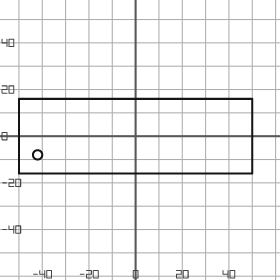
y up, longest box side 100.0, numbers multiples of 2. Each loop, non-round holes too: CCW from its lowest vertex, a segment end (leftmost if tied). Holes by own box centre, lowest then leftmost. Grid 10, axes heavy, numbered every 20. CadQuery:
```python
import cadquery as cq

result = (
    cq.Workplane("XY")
    .moveTo(-50.0, -16.0)
    .lineTo(50.0, -16.0)
    .lineTo(50.0, 16.0)
    .lineTo(-50.0, 16.0)
    .close()
    .moveTo(-42.0, -8.0)
    .circle(2.0)
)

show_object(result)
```